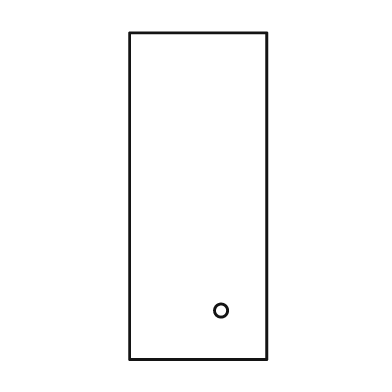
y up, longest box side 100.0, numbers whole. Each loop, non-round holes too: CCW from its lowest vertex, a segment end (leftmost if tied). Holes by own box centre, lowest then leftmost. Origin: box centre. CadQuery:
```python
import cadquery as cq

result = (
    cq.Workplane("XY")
    .moveTo(-21.0, -50.0)
    .lineTo(21.0, -50.0)
    .lineTo(21.0, 50.0)
    .lineTo(-21.0, 50.0)
    .close()
    .moveTo(7.0, -35.0)
    .circle(2.0)
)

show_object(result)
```